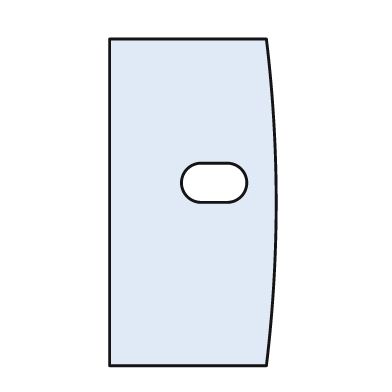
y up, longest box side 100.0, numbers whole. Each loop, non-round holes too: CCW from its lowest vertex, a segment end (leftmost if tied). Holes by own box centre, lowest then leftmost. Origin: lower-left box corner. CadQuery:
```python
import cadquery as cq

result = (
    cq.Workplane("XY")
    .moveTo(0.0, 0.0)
    .lineTo(48.0, 0.0)
    .threePointArc((51.0, 50.0), (48.0, 100.0))
    .lineTo(0.0, 100.0)
    .close()
    .moveTo(28.0, 50.0)
    .lineTo(36.0, 50.0)
    .threePointArc((42.0, 56.0), (36.0, 62.0))
    .lineTo(28.0, 62.0)
    .threePointArc((22.0, 56.0), (28.0, 50.0))
    .close()
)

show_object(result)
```